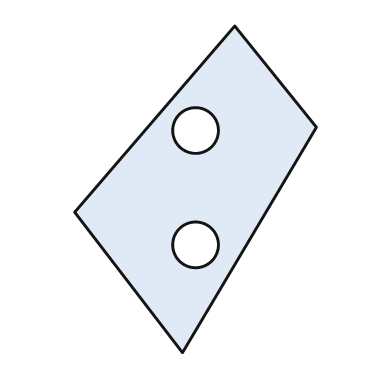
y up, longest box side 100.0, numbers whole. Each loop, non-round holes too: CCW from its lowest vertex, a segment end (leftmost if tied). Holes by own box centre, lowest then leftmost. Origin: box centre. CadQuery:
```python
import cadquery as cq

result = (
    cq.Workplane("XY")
    .moveTo(-4.0, -50.0)
    .lineTo(37.0, 19.0)
    .lineTo(12.0, 50.0)
    .lineTo(-37.0, -7.0)
    .close()
    .moveTo(0.0, -17.0)
    .circle(7.0)
    .moveTo(0.0, 18.0)
    .circle(7.0)
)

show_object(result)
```